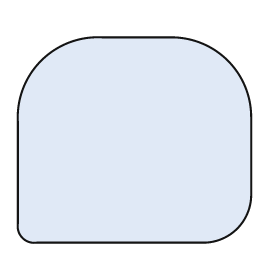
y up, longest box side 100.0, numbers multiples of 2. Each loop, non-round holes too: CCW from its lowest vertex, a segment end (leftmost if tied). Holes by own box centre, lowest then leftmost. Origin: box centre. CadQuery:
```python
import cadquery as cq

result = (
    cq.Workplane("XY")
    .moveTo(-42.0, -44.0)
    .lineTo(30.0, -44.0)
    .threePointArc((44.0, -38.0), (50.0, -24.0))
    .lineTo(50.0, 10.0)
    .threePointArc((40.0, 34.0), (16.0, 44.0))
    .lineTo(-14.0, 44.0)
    .threePointArc((-40.0, 34.0), (-50.0, 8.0))
    .lineTo(-50.0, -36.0)
    .threePointArc((-48.0, -42.0), (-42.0, -44.0))
    .close()
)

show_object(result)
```